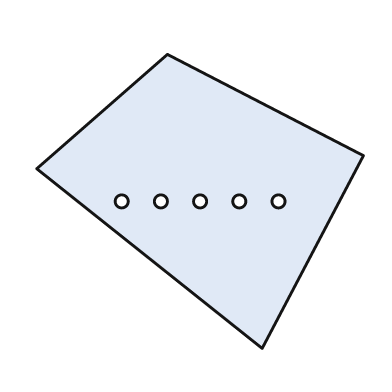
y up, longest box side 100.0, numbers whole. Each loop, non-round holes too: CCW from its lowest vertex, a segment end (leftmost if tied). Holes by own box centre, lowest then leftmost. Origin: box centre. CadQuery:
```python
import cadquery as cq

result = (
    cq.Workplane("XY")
    .moveTo(19.0, -45.0)
    .lineTo(50.0, 14.0)
    .lineTo(-10.0, 45.0)
    .lineTo(-50.0, 10.0)
    .close()
    .moveTo(-24.0, 0.0)
    .circle(2.0)
    .moveTo(-12.0, 0.0)
    .circle(2.0)
    .moveTo(0.0, 0.0)
    .circle(2.0)
    .moveTo(12.0, 0.0)
    .circle(2.0)
    .moveTo(24.0, 0.0)
    .circle(2.0)
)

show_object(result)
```